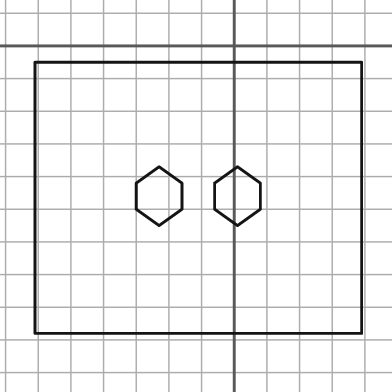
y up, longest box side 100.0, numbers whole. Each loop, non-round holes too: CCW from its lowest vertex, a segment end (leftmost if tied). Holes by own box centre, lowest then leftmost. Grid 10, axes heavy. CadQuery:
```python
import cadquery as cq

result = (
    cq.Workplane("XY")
    .moveTo(-61.0, -88.0)
    .lineTo(39.0, -88.0)
    .lineTo(39.0, -5.0)
    .lineTo(-61.0, -5.0)
    .close()
    .moveTo(-23.0, -55.0)
    .lineTo(-16.0, -50.0)
    .lineTo(-16.0, -42.0)
    .lineTo(-23.0, -37.0)
    .lineTo(-30.0, -42.0)
    .lineTo(-30.0, -50.0)
    .close()
    .moveTo(1.0, -55.0)
    .lineTo(8.0, -50.0)
    .lineTo(8.0, -42.0)
    .lineTo(1.0, -37.0)
    .lineTo(-6.0, -42.0)
    .lineTo(-6.0, -50.0)
    .close()
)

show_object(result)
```